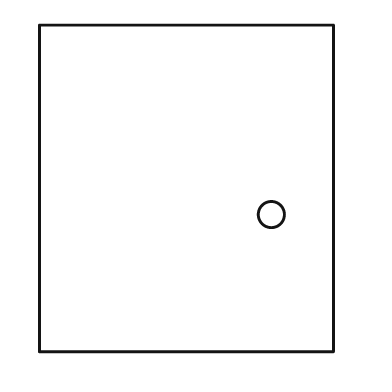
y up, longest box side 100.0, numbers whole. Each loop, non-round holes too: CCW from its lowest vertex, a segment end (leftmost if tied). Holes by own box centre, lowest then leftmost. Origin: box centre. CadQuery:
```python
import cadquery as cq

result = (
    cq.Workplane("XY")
    .moveTo(-45.0, -50.0)
    .lineTo(45.0, -50.0)
    .lineTo(45.0, 50.0)
    .lineTo(-45.0, 50.0)
    .close()
    .moveTo(26.0, -8.0)
    .circle(4.0)
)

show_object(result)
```